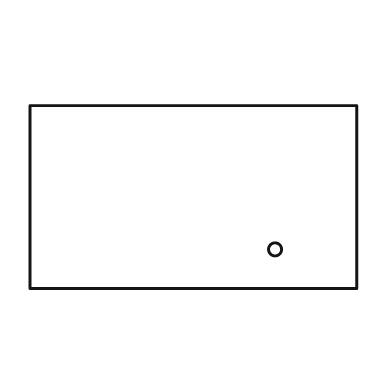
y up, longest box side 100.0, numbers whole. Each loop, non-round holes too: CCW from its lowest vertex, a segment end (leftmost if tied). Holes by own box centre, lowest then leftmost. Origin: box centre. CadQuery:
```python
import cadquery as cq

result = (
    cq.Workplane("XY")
    .moveTo(-50.0, -28.0)
    .lineTo(50.0, -28.0)
    .lineTo(50.0, 28.0)
    .lineTo(-50.0, 28.0)
    .close()
    .moveTo(25.0, -16.0)
    .circle(2.0)
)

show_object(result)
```